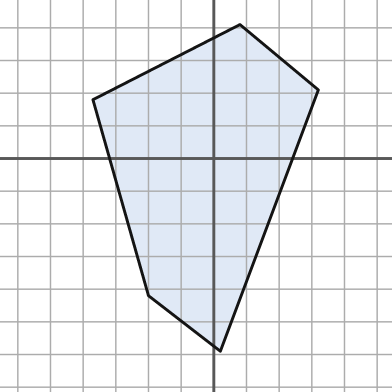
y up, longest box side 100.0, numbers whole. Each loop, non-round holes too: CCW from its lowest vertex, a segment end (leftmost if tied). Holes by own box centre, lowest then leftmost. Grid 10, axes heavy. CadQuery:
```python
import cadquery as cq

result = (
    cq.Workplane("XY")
    .moveTo(2.0, -59.0)
    .lineTo(32.0, 21.0)
    .lineTo(8.0, 41.0)
    .lineTo(-37.0, 18.0)
    .lineTo(-20.0, -42.0)
    .close()
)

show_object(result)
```